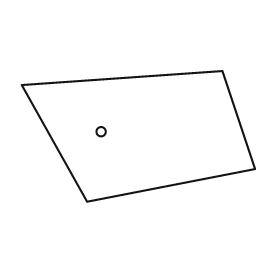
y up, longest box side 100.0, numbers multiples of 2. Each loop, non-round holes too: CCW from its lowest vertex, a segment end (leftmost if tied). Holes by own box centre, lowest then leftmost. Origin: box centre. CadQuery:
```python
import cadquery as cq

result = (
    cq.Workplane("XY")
    .moveTo(-22.0, -28.0)
    .lineTo(50.0, -14.0)
    .lineTo(36.0, 28.0)
    .lineTo(-50.0, 22.0)
    .close()
    .moveTo(-16.0, 2.0)
    .circle(2.0)
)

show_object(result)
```